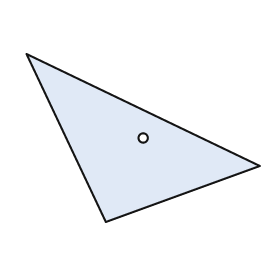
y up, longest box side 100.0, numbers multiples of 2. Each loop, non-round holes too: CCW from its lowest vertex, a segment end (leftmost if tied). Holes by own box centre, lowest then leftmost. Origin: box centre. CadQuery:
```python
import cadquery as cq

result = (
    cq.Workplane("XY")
    .moveTo(-16.0, -36.0)
    .lineTo(50.0, -12.0)
    .lineTo(-50.0, 36.0)
    .close()
    .moveTo(0.0, 0.0)
    .circle(2.0)
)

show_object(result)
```